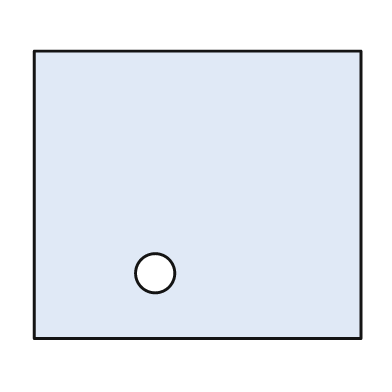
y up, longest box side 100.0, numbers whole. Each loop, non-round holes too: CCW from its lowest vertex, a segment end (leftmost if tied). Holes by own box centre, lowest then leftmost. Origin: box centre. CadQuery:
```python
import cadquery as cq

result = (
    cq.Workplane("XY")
    .moveTo(-50.0, -44.0)
    .lineTo(50.0, -44.0)
    .lineTo(50.0, 44.0)
    .lineTo(-50.0, 44.0)
    .close()
    .moveTo(-13.0, -24.0)
    .circle(6.0)
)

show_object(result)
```